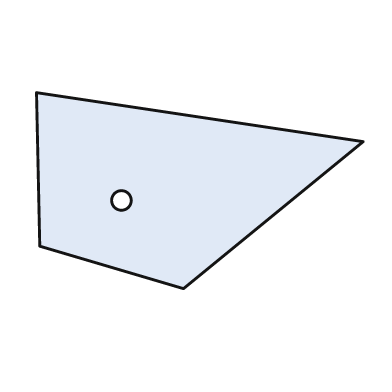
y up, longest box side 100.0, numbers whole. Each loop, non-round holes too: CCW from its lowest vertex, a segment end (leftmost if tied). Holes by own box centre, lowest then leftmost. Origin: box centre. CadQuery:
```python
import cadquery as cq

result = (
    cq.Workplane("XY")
    .moveTo(-5.0, -30.0)
    .lineTo(50.0, 15.0)
    .lineTo(-50.0, 30.0)
    .lineTo(-49.0, -17.0)
    .close()
    .moveTo(-24.0, -3.0)
    .circle(3.0)
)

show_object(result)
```